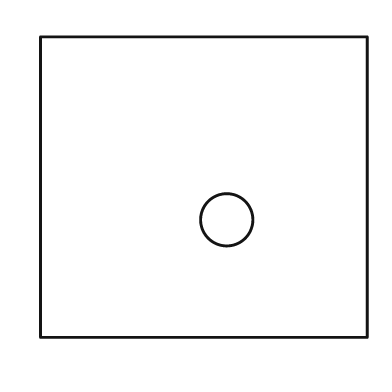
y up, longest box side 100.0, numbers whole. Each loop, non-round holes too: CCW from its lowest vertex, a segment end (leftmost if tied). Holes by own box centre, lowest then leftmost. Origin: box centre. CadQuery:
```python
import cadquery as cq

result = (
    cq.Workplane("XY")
    .moveTo(-50.0, -46.0)
    .lineTo(50.0, -46.0)
    .lineTo(50.0, 46.0)
    .lineTo(-50.0, 46.0)
    .close()
    .moveTo(7.0, -10.0)
    .circle(8.0)
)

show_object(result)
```